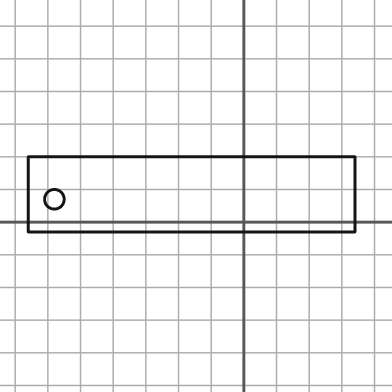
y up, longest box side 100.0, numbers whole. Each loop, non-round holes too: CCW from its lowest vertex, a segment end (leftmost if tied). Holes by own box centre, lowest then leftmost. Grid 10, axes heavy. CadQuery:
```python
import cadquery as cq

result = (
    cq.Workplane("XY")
    .moveTo(-66.0, -3.0)
    .lineTo(34.0, -3.0)
    .lineTo(34.0, 20.0)
    .lineTo(-66.0, 20.0)
    .close()
    .moveTo(-58.0, 7.0)
    .circle(3.0)
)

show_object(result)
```